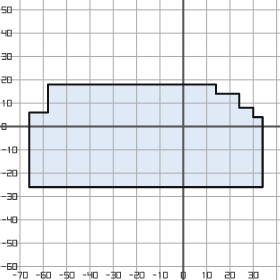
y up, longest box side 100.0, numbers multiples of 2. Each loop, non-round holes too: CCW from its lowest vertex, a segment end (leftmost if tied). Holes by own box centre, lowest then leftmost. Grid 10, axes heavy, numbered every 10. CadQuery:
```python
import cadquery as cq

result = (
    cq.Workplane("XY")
    .moveTo(-66.0, -26.0)
    .lineTo(34.0, -26.0)
    .lineTo(34.0, 4.0)
    .lineTo(30.0, 4.0)
    .lineTo(30.0, 8.0)
    .lineTo(24.0, 8.0)
    .lineTo(24.0, 14.0)
    .lineTo(14.0, 14.0)
    .lineTo(14.0, 18.0)
    .lineTo(-58.0, 18.0)
    .lineTo(-58.0, 6.0)
    .lineTo(-66.0, 6.0)
    .close()
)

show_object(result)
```